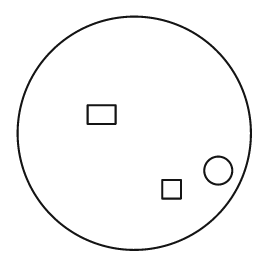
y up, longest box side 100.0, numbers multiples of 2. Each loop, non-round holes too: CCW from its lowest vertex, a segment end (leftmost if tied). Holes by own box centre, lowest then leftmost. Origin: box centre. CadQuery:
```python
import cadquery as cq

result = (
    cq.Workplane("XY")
    .moveTo(0.0, 0.0)
    .circle(50.0)
    .moveTo(12.0, -28.0)
    .lineTo(20.0, -28.0)
    .lineTo(20.0, -20.0)
    .lineTo(12.0, -20.0)
    .close()
    .moveTo(36.0, -16.0)
    .circle(6.0)
    .moveTo(-20.0, 4.0)
    .lineTo(-8.0, 4.0)
    .lineTo(-8.0, 12.0)
    .lineTo(-20.0, 12.0)
    .close()
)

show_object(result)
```